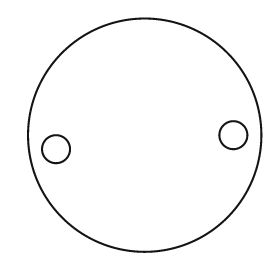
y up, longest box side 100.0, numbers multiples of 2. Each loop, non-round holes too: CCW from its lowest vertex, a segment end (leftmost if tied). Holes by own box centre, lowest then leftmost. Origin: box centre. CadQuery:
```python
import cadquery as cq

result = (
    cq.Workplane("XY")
    .moveTo(0.0, 0.0)
    .circle(50.0)
    .moveTo(-38.0, -6.0)
    .circle(6.0)
    .moveTo(38.0, 0.0)
    .circle(6.0)
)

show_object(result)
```